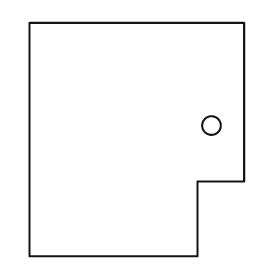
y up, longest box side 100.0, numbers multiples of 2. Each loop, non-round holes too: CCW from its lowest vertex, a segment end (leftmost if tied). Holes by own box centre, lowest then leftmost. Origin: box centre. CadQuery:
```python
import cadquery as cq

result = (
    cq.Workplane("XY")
    .moveTo(-46.0, -50.0)
    .lineTo(26.0, -50.0)
    .lineTo(26.0, -18.0)
    .lineTo(46.0, -18.0)
    .lineTo(46.0, 50.0)
    .lineTo(-46.0, 50.0)
    .close()
    .moveTo(32.0, 6.0)
    .circle(4.0)
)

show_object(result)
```